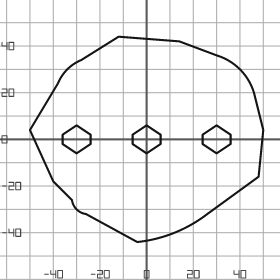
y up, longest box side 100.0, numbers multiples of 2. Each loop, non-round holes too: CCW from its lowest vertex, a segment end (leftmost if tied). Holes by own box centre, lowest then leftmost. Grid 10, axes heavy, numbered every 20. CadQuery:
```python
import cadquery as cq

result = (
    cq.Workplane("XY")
    .moveTo(-4.0, -44.0)
    .threePointArc((12.0, -40.0), (26.0, -32.0))
    .lineTo(48.0, -16.0)
    .lineTo(50.0, 4.0)
    .lineTo(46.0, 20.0)
    .threePointArc((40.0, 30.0), (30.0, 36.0))
    .lineTo(14.0, 42.0)
    .lineTo(-12.0, 44.0)
    .lineTo(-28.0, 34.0)
    .threePointArc((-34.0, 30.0), (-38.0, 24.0))
    .lineTo(-50.0, 4.0)
    .lineTo(-40.0, -18.0)
    .lineTo(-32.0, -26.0)
    .threePointArc((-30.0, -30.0), (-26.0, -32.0))
    .close()
    .moveTo(-30.0, -6.0)
    .lineTo(-24.0, -2.0)
    .lineTo(-24.0, 2.0)
    .lineTo(-30.0, 6.0)
    .lineTo(-36.0, 2.0)
    .lineTo(-36.0, -2.0)
    .close()
    .moveTo(0.0, -6.0)
    .lineTo(6.0, -2.0)
    .lineTo(6.0, 2.0)
    .lineTo(0.0, 6.0)
    .lineTo(-6.0, 2.0)
    .lineTo(-6.0, -2.0)
    .close()
    .moveTo(30.0, -6.0)
    .lineTo(36.0, -2.0)
    .lineTo(36.0, 2.0)
    .lineTo(30.0, 6.0)
    .lineTo(24.0, 2.0)
    .lineTo(24.0, -2.0)
    .close()
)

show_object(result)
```